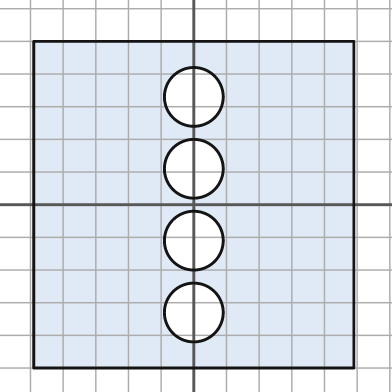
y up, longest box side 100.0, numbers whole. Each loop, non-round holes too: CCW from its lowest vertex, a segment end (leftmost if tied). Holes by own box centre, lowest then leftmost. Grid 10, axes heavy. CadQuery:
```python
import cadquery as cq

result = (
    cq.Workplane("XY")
    .moveTo(-49.0, -50.0)
    .lineTo(49.0, -50.0)
    .lineTo(49.0, 50.0)
    .lineTo(-49.0, 50.0)
    .close()
    .moveTo(0.0, -33.0)
    .circle(9.0)
    .moveTo(0.0, -11.0)
    .circle(9.0)
    .moveTo(0.0, 11.0)
    .circle(9.0)
    .moveTo(0.0, 33.0)
    .circle(9.0)
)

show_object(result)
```